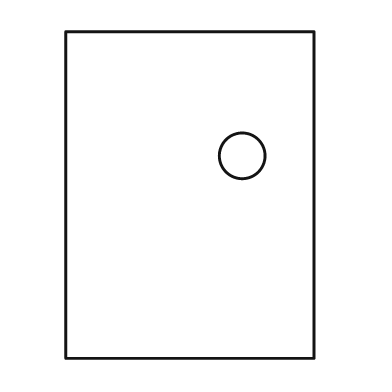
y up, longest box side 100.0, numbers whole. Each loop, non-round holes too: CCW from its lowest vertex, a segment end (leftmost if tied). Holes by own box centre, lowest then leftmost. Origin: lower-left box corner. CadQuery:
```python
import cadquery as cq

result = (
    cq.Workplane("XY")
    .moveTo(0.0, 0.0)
    .lineTo(76.0, 0.0)
    .lineTo(76.0, 100.0)
    .lineTo(0.0, 100.0)
    .close()
    .moveTo(54.0, 62.0)
    .circle(7.0)
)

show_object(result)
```